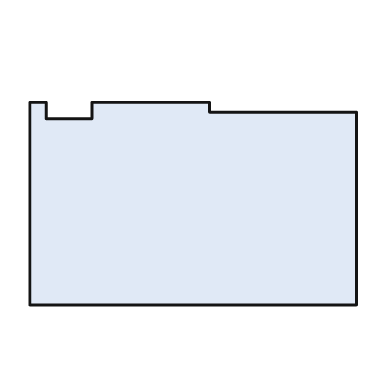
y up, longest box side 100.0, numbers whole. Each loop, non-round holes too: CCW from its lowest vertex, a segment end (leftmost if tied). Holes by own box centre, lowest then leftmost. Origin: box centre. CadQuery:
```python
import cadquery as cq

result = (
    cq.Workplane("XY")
    .moveTo(-50.0, -31.0)
    .lineTo(50.0, -31.0)
    .lineTo(50.0, 28.0)
    .lineTo(5.0, 28.0)
    .lineTo(5.0, 31.0)
    .lineTo(-31.0, 31.0)
    .lineTo(-31.0, 26.0)
    .lineTo(-45.0, 26.0)
    .lineTo(-45.0, 31.0)
    .lineTo(-50.0, 31.0)
    .close()
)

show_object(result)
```